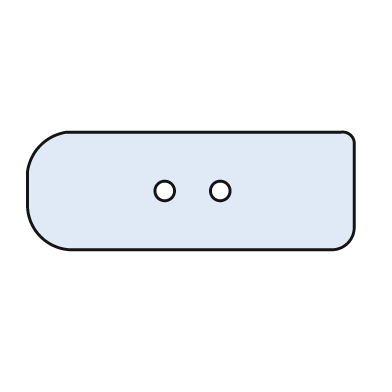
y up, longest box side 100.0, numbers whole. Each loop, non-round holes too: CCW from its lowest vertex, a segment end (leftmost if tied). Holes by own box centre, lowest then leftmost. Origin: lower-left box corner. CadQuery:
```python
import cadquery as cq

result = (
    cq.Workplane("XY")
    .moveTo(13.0, 0.0)
    .lineTo(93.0, 0.0)
    .threePointArc((98.0, 2.0), (100.0, 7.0))
    .lineTo(100.0, 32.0)
    .threePointArc((99.0, 35.0), (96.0, 36.0))
    .lineTo(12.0, 36.0)
    .threePointArc((4.0, 32.0), (0.0, 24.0))
    .lineTo(0.0, 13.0)
    .threePointArc((4.0, 4.0), (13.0, 0.0))
    .close()
    .moveTo(42.0, 18.0)
    .circle(3.0)
    .moveTo(59.0, 18.0)
    .circle(3.0)
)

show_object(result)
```